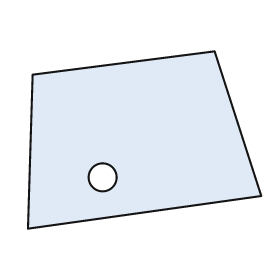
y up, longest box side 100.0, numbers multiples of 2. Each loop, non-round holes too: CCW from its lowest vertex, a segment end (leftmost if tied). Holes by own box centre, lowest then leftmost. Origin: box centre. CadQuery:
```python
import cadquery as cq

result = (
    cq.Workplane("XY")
    .moveTo(-50.0, -38.0)
    .lineTo(50.0, -24.0)
    .lineTo(30.0, 38.0)
    .lineTo(-48.0, 28.0)
    .close()
    .moveTo(-18.0, -16.0)
    .circle(6.0)
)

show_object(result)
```